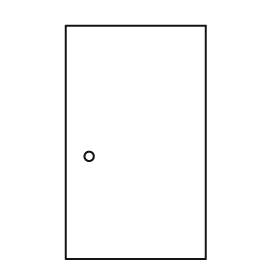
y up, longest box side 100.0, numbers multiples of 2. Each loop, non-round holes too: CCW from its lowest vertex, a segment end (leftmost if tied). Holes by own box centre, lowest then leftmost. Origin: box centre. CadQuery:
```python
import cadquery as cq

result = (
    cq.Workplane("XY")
    .moveTo(-30.0, -50.0)
    .lineTo(30.0, -50.0)
    .lineTo(30.0, 50.0)
    .lineTo(-30.0, 50.0)
    .close()
    .moveTo(-20.0, -6.0)
    .circle(2.0)
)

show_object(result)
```